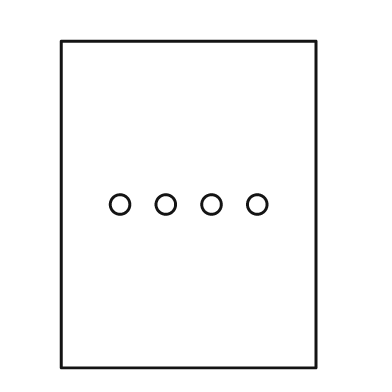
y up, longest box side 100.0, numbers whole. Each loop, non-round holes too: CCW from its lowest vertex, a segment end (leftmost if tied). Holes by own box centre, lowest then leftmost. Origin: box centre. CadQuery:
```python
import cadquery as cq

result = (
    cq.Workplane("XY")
    .moveTo(-39.0, -50.0)
    .lineTo(39.0, -50.0)
    .lineTo(39.0, 50.0)
    .lineTo(-39.0, 50.0)
    .close()
    .moveTo(-21.0, 0.0)
    .circle(3.0)
    .moveTo(-7.0, 0.0)
    .circle(3.0)
    .moveTo(7.0, 0.0)
    .circle(3.0)
    .moveTo(21.0, 0.0)
    .circle(3.0)
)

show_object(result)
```